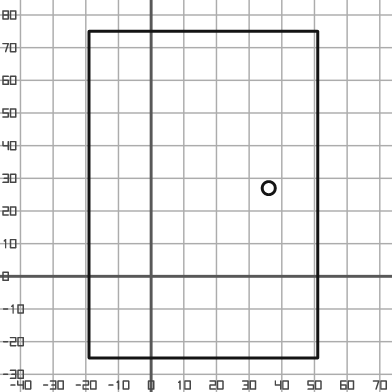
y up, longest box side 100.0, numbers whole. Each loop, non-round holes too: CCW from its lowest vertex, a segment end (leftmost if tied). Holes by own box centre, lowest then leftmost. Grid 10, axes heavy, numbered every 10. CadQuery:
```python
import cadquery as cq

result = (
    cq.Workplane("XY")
    .moveTo(-19.0, -25.0)
    .lineTo(51.0, -25.0)
    .lineTo(51.0, 75.0)
    .lineTo(-19.0, 75.0)
    .close()
    .moveTo(36.0, 27.0)
    .circle(2.0)
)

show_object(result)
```